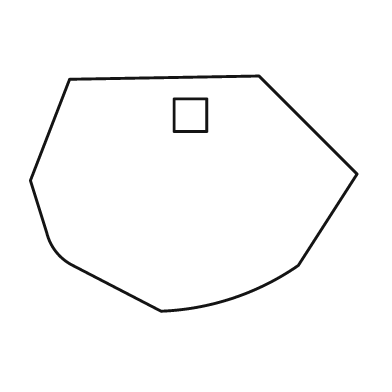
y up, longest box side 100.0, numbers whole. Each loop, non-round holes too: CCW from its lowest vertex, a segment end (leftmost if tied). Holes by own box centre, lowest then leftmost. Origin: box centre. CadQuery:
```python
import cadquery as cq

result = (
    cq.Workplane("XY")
    .moveTo(-10.0, -36.0)
    .threePointArc((12.0, -32.0), (32.0, -22.0))
    .lineTo(50.0, 6.0)
    .lineTo(20.0, 36.0)
    .lineTo(-38.0, 35.0)
    .lineTo(-50.0, 4.0)
    .lineTo(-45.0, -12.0)
    .threePointArc((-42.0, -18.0), (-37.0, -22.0))
    .close()
    .moveTo(-6.0, 19.0)
    .lineTo(4.0, 19.0)
    .lineTo(4.0, 29.0)
    .lineTo(-6.0, 29.0)
    .close()
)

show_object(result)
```